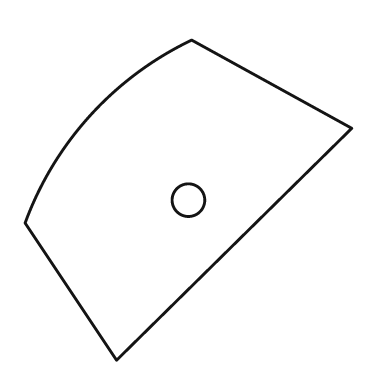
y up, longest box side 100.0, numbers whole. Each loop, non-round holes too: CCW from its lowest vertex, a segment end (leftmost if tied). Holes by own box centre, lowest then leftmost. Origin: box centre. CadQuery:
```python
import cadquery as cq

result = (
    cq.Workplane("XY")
    .moveTo(-22.0, -49.0)
    .lineTo(50.0, 22.0)
    .lineTo(1.0, 49.0)
    .threePointArc((-30.0, 26.0), (-50.0, -7.0))
    .close()
    .moveTo(0.0, 0.0)
    .circle(5.0)
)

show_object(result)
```